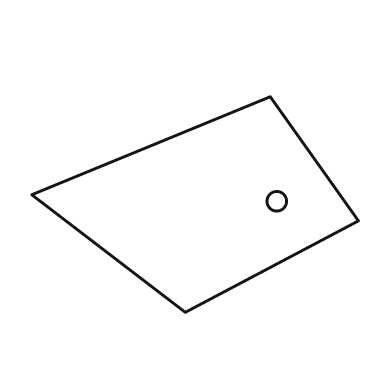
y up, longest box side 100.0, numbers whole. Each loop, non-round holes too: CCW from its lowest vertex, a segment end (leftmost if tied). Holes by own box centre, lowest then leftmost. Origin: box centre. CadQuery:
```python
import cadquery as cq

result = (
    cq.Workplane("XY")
    .moveTo(-3.0, -33.0)
    .lineTo(50.0, -5.0)
    .lineTo(23.0, 33.0)
    .lineTo(-50.0, 3.0)
    .close()
    .moveTo(25.0, 1.0)
    .circle(3.0)
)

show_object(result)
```